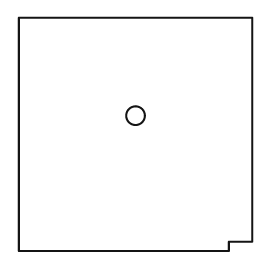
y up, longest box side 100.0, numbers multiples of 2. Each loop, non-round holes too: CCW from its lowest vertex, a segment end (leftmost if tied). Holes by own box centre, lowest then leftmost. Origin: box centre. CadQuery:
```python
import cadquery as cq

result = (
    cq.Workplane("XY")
    .moveTo(-50.0, -50.0)
    .lineTo(40.0, -50.0)
    .lineTo(40.0, -46.0)
    .lineTo(50.0, -46.0)
    .lineTo(50.0, 50.0)
    .lineTo(-50.0, 50.0)
    .close()
    .moveTo(0.0, 8.0)
    .circle(4.0)
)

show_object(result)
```